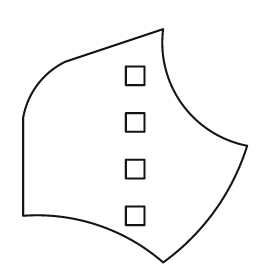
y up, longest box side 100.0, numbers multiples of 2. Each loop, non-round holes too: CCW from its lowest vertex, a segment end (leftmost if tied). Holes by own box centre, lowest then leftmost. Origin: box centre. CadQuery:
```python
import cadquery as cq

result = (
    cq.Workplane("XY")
    .moveTo(12.0, -50.0)
    .threePointArc((34.0, -28.0), (48.0, 0.0))
    .threePointArc((20.0, 18.0), (12.0, 50.0))
    .lineTo(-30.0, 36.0)
    .threePointArc((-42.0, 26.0), (-48.0, 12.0))
    .lineTo(-48.0, -30.0)
    .threePointArc((-16.0, -34.0), (12.0, -50.0))
    .close()
    .moveTo(-4.0, -34.0)
    .lineTo(4.0, -34.0)
    .lineTo(4.0, -26.0)
    .lineTo(-4.0, -26.0)
    .close()
    .moveTo(-4.0, -14.0)
    .lineTo(4.0, -14.0)
    .lineTo(4.0, -6.0)
    .lineTo(-4.0, -6.0)
    .close()
    .moveTo(-4.0, 6.0)
    .lineTo(4.0, 6.0)
    .lineTo(4.0, 14.0)
    .lineTo(-4.0, 14.0)
    .close()
    .moveTo(-4.0, 26.0)
    .lineTo(4.0, 26.0)
    .lineTo(4.0, 34.0)
    .lineTo(-4.0, 34.0)
    .close()
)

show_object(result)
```